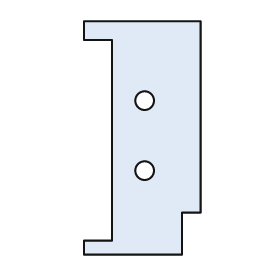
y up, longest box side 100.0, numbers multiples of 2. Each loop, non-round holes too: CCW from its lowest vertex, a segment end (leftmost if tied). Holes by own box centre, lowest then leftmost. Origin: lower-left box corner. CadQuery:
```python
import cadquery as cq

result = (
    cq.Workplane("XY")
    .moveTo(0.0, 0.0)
    .lineTo(42.0, 0.0)
    .lineTo(42.0, 18.0)
    .lineTo(50.0, 18.0)
    .lineTo(50.0, 100.0)
    .lineTo(0.0, 100.0)
    .lineTo(0.0, 92.0)
    .lineTo(12.0, 92.0)
    .lineTo(12.0, 6.0)
    .lineTo(0.0, 6.0)
    .close()
    .moveTo(26.0, 36.0)
    .circle(4.0)
    .moveTo(26.0, 66.0)
    .circle(4.0)
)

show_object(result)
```